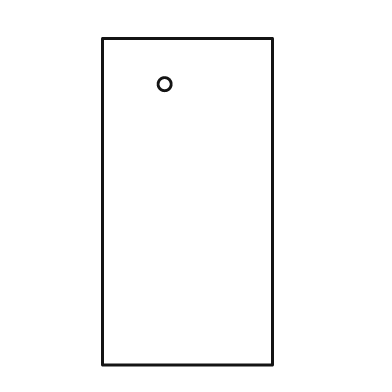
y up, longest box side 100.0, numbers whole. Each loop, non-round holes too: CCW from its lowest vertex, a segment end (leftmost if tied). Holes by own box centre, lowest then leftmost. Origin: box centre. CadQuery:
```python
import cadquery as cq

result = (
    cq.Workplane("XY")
    .moveTo(-26.0, -50.0)
    .lineTo(26.0, -50.0)
    .lineTo(26.0, 50.0)
    .lineTo(-26.0, 50.0)
    .close()
    .moveTo(-7.0, 36.0)
    .circle(2.0)
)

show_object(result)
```